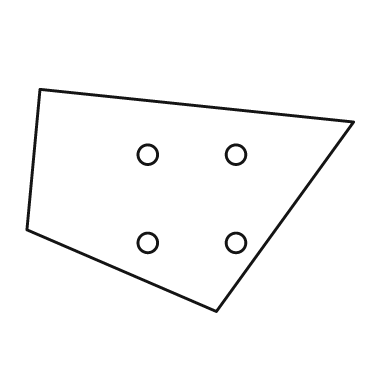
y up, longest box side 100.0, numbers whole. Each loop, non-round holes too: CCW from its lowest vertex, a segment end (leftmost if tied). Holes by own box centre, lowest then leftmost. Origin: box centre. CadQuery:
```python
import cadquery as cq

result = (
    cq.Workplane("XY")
    .moveTo(8.0, -34.0)
    .lineTo(50.0, 24.0)
    .lineTo(-46.0, 34.0)
    .lineTo(-50.0, -9.0)
    .close()
    .moveTo(-13.0, -13.0)
    .circle(3.0)
    .moveTo(14.0, -13.0)
    .circle(3.0)
    .moveTo(-13.0, 14.0)
    .circle(3.0)
    .moveTo(14.0, 14.0)
    .circle(3.0)
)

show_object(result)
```